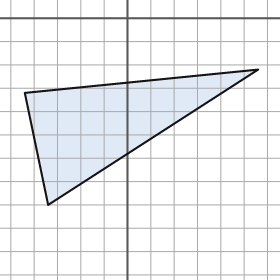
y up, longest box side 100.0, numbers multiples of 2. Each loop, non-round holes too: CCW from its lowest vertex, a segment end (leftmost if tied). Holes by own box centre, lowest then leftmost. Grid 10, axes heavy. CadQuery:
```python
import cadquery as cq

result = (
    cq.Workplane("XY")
    .moveTo(-34.0, -80.0)
    .lineTo(56.0, -22.0)
    .lineTo(-44.0, -32.0)
    .close()
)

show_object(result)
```